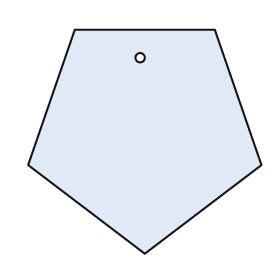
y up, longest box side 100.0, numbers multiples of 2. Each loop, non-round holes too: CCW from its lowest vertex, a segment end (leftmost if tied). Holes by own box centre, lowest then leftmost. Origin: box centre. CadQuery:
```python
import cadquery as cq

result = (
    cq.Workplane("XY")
    .moveTo(0.0, -48.0)
    .lineTo(50.0, -10.0)
    .lineTo(30.0, 48.0)
    .lineTo(-30.0, 48.0)
    .lineTo(-50.0, -10.0)
    .close()
    .moveTo(-2.0, 36.0)
    .circle(2.0)
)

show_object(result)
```